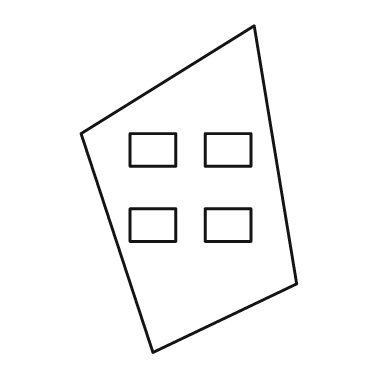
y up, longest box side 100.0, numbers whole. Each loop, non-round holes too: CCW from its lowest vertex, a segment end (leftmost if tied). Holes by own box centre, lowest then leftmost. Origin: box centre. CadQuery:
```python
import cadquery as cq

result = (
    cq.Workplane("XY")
    .moveTo(-11.0, -50.0)
    .lineTo(33.0, -29.0)
    .lineTo(20.0, 50.0)
    .lineTo(-33.0, 17.0)
    .close()
    .moveTo(-18.0, -16.0)
    .lineTo(-4.0, -16.0)
    .lineTo(-4.0, -6.0)
    .lineTo(-18.0, -6.0)
    .close()
    .moveTo(5.0, -16.0)
    .lineTo(19.0, -16.0)
    .lineTo(19.0, -6.0)
    .lineTo(5.0, -6.0)
    .close()
    .moveTo(-18.0, 7.0)
    .lineTo(-4.0, 7.0)
    .lineTo(-4.0, 17.0)
    .lineTo(-18.0, 17.0)
    .close()
    .moveTo(5.0, 7.0)
    .lineTo(19.0, 7.0)
    .lineTo(19.0, 17.0)
    .lineTo(5.0, 17.0)
    .close()
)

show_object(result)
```